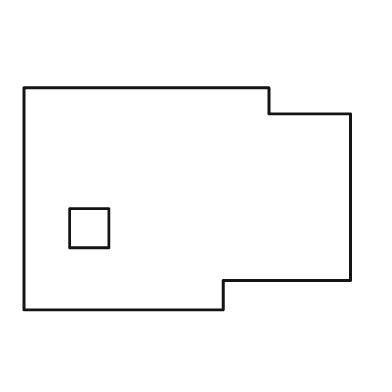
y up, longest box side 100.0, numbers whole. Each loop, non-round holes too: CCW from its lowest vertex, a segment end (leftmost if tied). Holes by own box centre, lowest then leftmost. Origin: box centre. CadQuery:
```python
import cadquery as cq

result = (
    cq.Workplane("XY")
    .moveTo(-50.0, -34.0)
    .lineTo(11.0, -34.0)
    .lineTo(11.0, -25.0)
    .lineTo(50.0, -25.0)
    .lineTo(50.0, 26.0)
    .lineTo(25.0, 26.0)
    .lineTo(25.0, 34.0)
    .lineTo(-50.0, 34.0)
    .close()
    .moveTo(-36.0, -15.0)
    .lineTo(-24.0, -15.0)
    .lineTo(-24.0, -3.0)
    .lineTo(-36.0, -3.0)
    .close()
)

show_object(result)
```